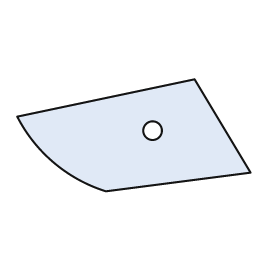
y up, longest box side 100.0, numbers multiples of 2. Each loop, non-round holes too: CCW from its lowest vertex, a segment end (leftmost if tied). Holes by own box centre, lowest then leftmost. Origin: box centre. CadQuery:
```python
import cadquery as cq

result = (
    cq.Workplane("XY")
    .moveTo(-12.0, -24.0)
    .lineTo(50.0, -16.0)
    .lineTo(26.0, 24.0)
    .lineTo(-50.0, 8.0)
    .threePointArc((-34.0, -12.0), (-12.0, -24.0))
    .close()
    .moveTo(8.0, 2.0)
    .circle(4.0)
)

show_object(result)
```